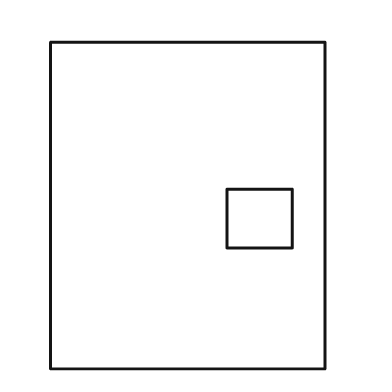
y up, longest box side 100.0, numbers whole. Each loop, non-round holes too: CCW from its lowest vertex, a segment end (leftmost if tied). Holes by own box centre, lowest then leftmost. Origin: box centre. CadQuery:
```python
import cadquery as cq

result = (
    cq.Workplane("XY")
    .moveTo(-42.0, -50.0)
    .lineTo(42.0, -50.0)
    .lineTo(42.0, 50.0)
    .lineTo(-42.0, 50.0)
    .close()
    .moveTo(12.0, -13.0)
    .lineTo(32.0, -13.0)
    .lineTo(32.0, 5.0)
    .lineTo(12.0, 5.0)
    .close()
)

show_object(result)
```